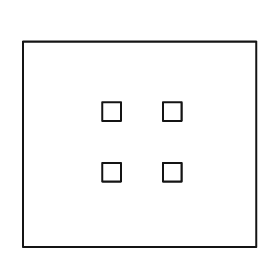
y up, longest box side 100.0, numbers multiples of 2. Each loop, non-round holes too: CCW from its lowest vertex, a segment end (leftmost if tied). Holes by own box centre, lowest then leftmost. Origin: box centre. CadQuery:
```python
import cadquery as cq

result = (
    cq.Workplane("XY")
    .moveTo(-50.0, -44.0)
    .lineTo(50.0, -44.0)
    .lineTo(50.0, 44.0)
    .lineTo(-50.0, 44.0)
    .close()
    .moveTo(-16.0, -16.0)
    .lineTo(-8.0, -16.0)
    .lineTo(-8.0, -8.0)
    .lineTo(-16.0, -8.0)
    .close()
    .moveTo(10.0, -16.0)
    .lineTo(18.0, -16.0)
    .lineTo(18.0, -8.0)
    .lineTo(10.0, -8.0)
    .close()
    .moveTo(-16.0, 10.0)
    .lineTo(-8.0, 10.0)
    .lineTo(-8.0, 18.0)
    .lineTo(-16.0, 18.0)
    .close()
    .moveTo(10.0, 10.0)
    .lineTo(18.0, 10.0)
    .lineTo(18.0, 18.0)
    .lineTo(10.0, 18.0)
    .close()
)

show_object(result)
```